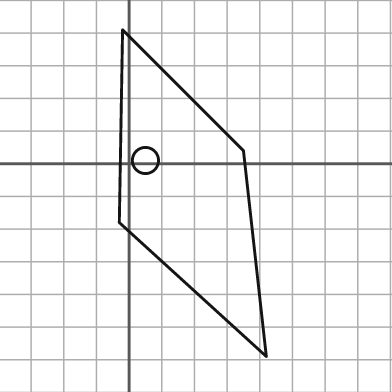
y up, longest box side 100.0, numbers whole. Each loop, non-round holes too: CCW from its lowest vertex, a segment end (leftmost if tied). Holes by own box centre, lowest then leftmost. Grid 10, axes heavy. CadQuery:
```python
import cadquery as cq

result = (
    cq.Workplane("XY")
    .moveTo(42.0, -59.0)
    .lineTo(35.0, 4.0)
    .lineTo(-2.0, 41.0)
    .lineTo(-3.0, -18.0)
    .close()
    .moveTo(5.0, 1.0)
    .circle(4.0)
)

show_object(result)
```